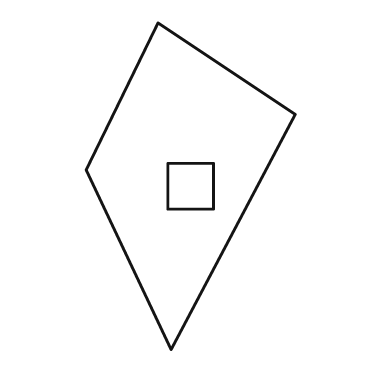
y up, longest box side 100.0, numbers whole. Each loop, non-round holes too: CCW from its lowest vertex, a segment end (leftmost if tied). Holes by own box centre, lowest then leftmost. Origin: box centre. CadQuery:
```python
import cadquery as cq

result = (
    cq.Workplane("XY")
    .moveTo(-6.0, -50.0)
    .lineTo(32.0, 22.0)
    .lineTo(-10.0, 50.0)
    .lineTo(-32.0, 5.0)
    .close()
    .moveTo(-7.0, -7.0)
    .lineTo(7.0, -7.0)
    .lineTo(7.0, 7.0)
    .lineTo(-7.0, 7.0)
    .close()
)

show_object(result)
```